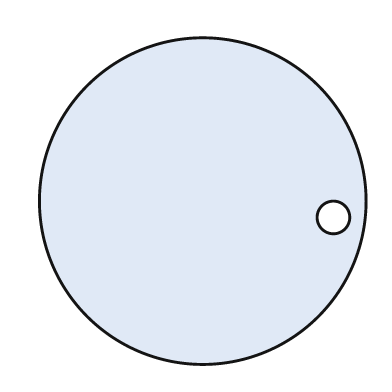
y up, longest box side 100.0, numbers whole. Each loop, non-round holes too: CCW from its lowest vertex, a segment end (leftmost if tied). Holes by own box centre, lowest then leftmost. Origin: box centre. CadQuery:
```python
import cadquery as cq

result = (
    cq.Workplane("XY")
    .moveTo(0.0, 0.0)
    .circle(50.0)
    .moveTo(40.0, -5.0)
    .circle(5.0)
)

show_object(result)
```